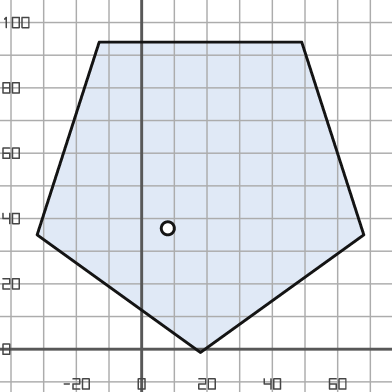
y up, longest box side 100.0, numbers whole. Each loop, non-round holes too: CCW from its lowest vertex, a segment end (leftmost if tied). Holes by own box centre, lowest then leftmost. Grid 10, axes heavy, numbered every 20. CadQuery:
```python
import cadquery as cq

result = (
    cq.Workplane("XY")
    .moveTo(18.0, -1.0)
    .lineTo(68.0, 35.0)
    .lineTo(49.0, 94.0)
    .lineTo(-13.0, 94.0)
    .lineTo(-32.0, 35.0)
    .close()
    .moveTo(8.0, 37.0)
    .circle(2.0)
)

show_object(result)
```